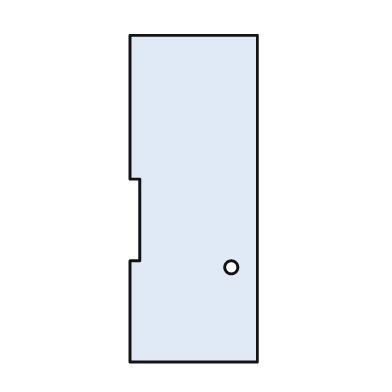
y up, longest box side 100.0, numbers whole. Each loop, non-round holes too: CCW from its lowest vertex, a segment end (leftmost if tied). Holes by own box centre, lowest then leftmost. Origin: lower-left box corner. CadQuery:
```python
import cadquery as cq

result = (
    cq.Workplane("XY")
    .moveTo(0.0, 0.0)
    .lineTo(39.0, 0.0)
    .lineTo(39.0, 100.0)
    .lineTo(0.0, 100.0)
    .lineTo(0.0, 56.0)
    .lineTo(3.0, 56.0)
    .lineTo(3.0, 31.0)
    .lineTo(0.0, 31.0)
    .close()
    .moveTo(31.0, 29.0)
    .circle(2.0)
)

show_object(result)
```